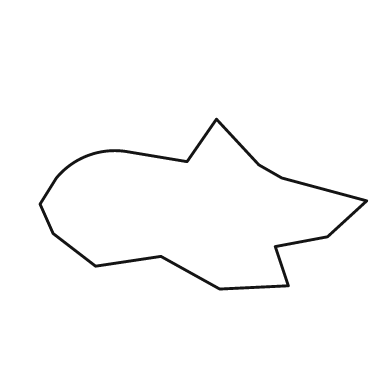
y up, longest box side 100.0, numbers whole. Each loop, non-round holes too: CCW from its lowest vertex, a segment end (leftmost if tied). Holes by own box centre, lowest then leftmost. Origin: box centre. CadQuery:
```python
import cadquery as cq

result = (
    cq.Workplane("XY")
    .moveTo(5.0, -26.0)
    .lineTo(26.0, -25.0)
    .lineTo(22.0, -13.0)
    .lineTo(38.0, -10.0)
    .lineTo(50.0, 1.0)
    .lineTo(24.0, 8.0)
    .lineTo(17.0, 12.0)
    .lineTo(4.0, 26.0)
    .lineTo(-5.0, 13.0)
    .lineTo(-23.0, 16.0)
    .threePointArc((-35.0, 15.0), (-45.0, 8.0))
    .lineTo(-50.0, 0.0)
    .lineTo(-46.0, -9.0)
    .lineTo(-33.0, -19.0)
    .lineTo(-13.0, -16.0)
    .close()
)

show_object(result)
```